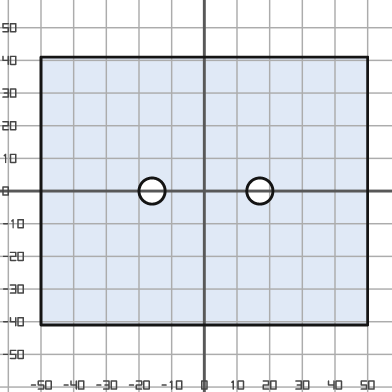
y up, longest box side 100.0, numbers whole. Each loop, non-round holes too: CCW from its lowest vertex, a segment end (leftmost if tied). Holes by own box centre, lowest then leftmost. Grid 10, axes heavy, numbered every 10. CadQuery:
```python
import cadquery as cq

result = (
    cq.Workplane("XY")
    .moveTo(-50.0, -41.0)
    .lineTo(50.0, -41.0)
    .lineTo(50.0, 41.0)
    .lineTo(-50.0, 41.0)
    .close()
    .moveTo(-16.0, 0.0)
    .circle(4.0)
    .moveTo(17.0, 0.0)
    .circle(4.0)
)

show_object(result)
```